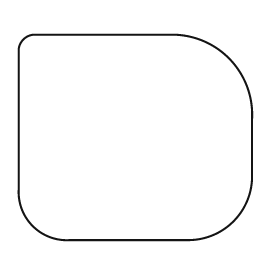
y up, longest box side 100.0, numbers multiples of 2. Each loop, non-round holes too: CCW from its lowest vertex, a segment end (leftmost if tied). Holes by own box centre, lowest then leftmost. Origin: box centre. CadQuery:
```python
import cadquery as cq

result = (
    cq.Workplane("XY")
    .moveTo(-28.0, -44.0)
    .lineTo(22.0, -44.0)
    .threePointArc((42.0, -36.0), (50.0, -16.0))
    .lineTo(50.0, 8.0)
    .threePointArc((40.0, 34.0), (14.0, 44.0))
    .lineTo(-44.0, 44.0)
    .threePointArc((-48.0, 42.0), (-50.0, 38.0))
    .lineTo(-50.0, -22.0)
    .threePointArc((-44.0, -38.0), (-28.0, -44.0))
    .close()
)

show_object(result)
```